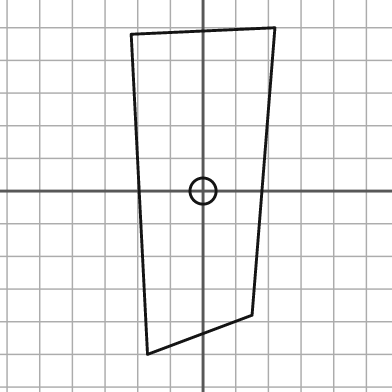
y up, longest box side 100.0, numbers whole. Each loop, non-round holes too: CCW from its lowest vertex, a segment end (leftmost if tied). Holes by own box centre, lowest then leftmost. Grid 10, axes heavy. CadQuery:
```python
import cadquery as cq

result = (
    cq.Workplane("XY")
    .moveTo(-17.0, -50.0)
    .lineTo(15.0, -38.0)
    .lineTo(22.0, 50.0)
    .lineTo(-22.0, 48.0)
    .close()
    .moveTo(0.0, 0.0)
    .circle(4.0)
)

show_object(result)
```